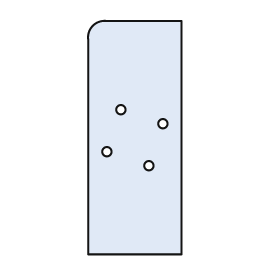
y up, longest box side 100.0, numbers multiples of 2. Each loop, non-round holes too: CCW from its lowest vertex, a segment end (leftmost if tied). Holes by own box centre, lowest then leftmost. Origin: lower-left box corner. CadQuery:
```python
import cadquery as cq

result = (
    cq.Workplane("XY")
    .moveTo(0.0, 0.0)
    .lineTo(40.0, 0.0)
    .lineTo(40.0, 100.0)
    .lineTo(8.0, 100.0)
    .threePointArc((2.0, 98.0), (0.0, 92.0))
    .close()
    .moveTo(26.0, 38.0)
    .circle(2.0)
    .moveTo(8.0, 44.0)
    .circle(2.0)
    .moveTo(32.0, 56.0)
    .circle(2.0)
    .moveTo(14.0, 62.0)
    .circle(2.0)
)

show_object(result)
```